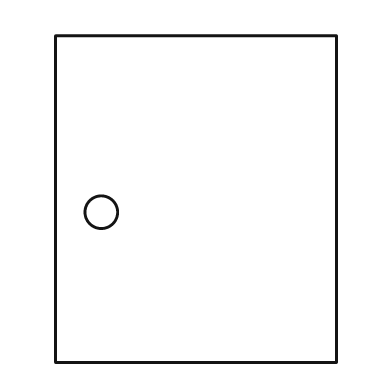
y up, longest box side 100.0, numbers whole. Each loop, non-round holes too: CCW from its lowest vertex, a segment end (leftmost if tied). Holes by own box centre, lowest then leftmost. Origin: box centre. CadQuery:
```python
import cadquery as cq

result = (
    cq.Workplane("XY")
    .moveTo(-43.0, -50.0)
    .lineTo(43.0, -50.0)
    .lineTo(43.0, 50.0)
    .lineTo(-43.0, 50.0)
    .close()
    .moveTo(-29.0, -4.0)
    .circle(5.0)
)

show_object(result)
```